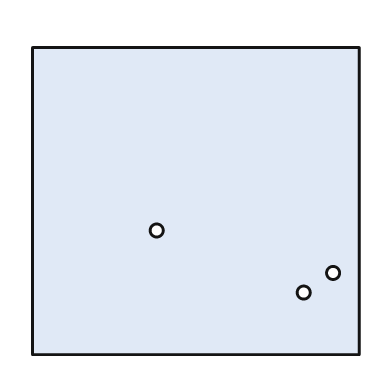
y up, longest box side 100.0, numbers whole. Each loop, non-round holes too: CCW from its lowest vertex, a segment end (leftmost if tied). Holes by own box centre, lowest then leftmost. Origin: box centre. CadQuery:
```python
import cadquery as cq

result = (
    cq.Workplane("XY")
    .moveTo(-50.0, -47.0)
    .lineTo(50.0, -47.0)
    .lineTo(50.0, 47.0)
    .lineTo(-50.0, 47.0)
    .close()
    .moveTo(33.0, -28.0)
    .circle(2.0)
    .moveTo(42.0, -22.0)
    .circle(2.0)
    .moveTo(-12.0, -9.0)
    .circle(2.0)
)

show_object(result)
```